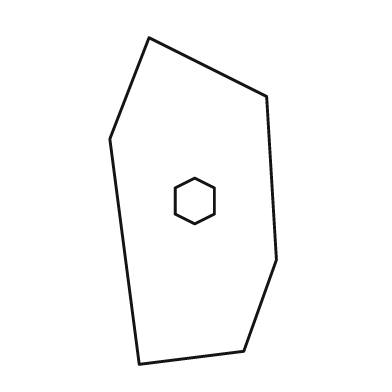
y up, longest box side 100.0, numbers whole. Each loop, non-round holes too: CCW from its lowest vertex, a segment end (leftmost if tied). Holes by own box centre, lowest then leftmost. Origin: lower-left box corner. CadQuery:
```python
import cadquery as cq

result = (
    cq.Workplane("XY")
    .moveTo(9.0, 0.0)
    .lineTo(41.0, 4.0)
    .lineTo(51.0, 32.0)
    .lineTo(48.0, 82.0)
    .lineTo(12.0, 100.0)
    .lineTo(0.0, 69.0)
    .close()
    .moveTo(26.0, 43.0)
    .lineTo(32.0, 46.0)
    .lineTo(32.0, 54.0)
    .lineTo(26.0, 57.0)
    .lineTo(20.0, 54.0)
    .lineTo(20.0, 46.0)
    .close()
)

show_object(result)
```